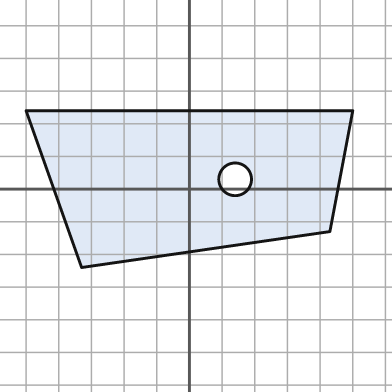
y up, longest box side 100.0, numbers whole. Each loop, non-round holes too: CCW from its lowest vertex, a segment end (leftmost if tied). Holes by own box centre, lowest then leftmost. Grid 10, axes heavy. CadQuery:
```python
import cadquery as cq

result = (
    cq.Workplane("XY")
    .moveTo(-33.0, -24.0)
    .lineTo(43.0, -13.0)
    .lineTo(50.0, 24.0)
    .lineTo(-50.0, 24.0)
    .close()
    .moveTo(14.0, 3.0)
    .circle(5.0)
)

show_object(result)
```